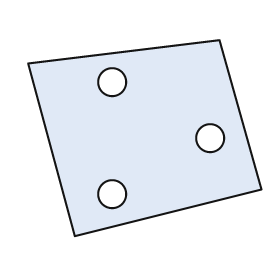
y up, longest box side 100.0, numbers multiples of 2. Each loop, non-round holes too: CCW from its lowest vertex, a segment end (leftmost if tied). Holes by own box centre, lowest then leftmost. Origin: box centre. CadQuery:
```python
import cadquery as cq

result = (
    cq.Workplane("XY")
    .moveTo(-30.0, -42.0)
    .lineTo(50.0, -22.0)
    .lineTo(32.0, 42.0)
    .lineTo(-50.0, 32.0)
    .close()
    .moveTo(-14.0, -24.0)
    .circle(6.0)
    .moveTo(28.0, 0.0)
    .circle(6.0)
    .moveTo(-14.0, 24.0)
    .circle(6.0)
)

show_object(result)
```